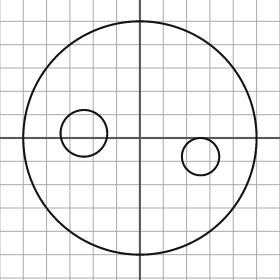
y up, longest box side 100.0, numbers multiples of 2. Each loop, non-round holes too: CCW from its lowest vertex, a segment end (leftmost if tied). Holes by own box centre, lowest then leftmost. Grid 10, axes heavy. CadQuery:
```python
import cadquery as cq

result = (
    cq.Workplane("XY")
    .moveTo(0.0, 0.0)
    .circle(50.0)
    .moveTo(26.0, -8.0)
    .circle(8.0)
    .moveTo(-24.0, 2.0)
    .circle(10.0)
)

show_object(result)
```